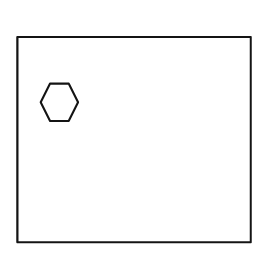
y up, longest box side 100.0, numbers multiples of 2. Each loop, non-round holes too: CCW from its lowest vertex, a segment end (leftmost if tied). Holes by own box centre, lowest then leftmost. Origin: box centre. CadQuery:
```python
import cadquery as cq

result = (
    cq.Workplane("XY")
    .moveTo(-50.0, -44.0)
    .lineTo(50.0, -44.0)
    .lineTo(50.0, 44.0)
    .lineTo(-50.0, 44.0)
    .close()
    .moveTo(-36.0, 8.0)
    .lineTo(-28.0, 8.0)
    .lineTo(-24.0, 16.0)
    .lineTo(-28.0, 24.0)
    .lineTo(-36.0, 24.0)
    .lineTo(-40.0, 16.0)
    .close()
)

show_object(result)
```